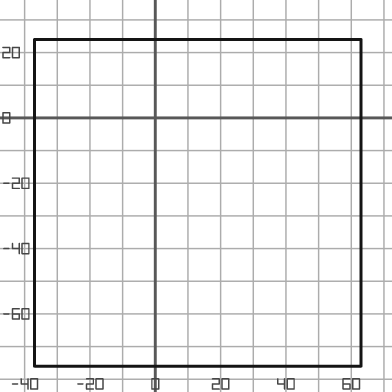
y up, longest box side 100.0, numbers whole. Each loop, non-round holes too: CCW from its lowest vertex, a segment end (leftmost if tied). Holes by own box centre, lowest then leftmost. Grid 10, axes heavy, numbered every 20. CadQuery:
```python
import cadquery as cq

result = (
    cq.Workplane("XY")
    .moveTo(-37.0, -76.0)
    .lineTo(63.0, -76.0)
    .lineTo(63.0, 24.0)
    .lineTo(-37.0, 24.0)
    .close()
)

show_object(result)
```